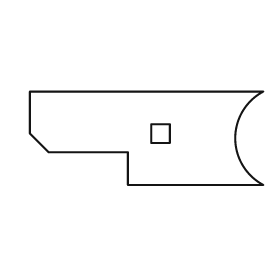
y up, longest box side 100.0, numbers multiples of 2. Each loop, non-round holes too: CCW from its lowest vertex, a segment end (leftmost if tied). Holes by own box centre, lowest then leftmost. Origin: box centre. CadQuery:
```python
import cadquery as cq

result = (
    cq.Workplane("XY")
    .moveTo(-8.0, -20.0)
    .lineTo(50.0, -20.0)
    .threePointArc((38.0, 0.0), (50.0, 20.0))
    .lineTo(-50.0, 20.0)
    .lineTo(-50.0, 2.0)
    .lineTo(-42.0, -6.0)
    .lineTo(-8.0, -6.0)
    .close()
    .moveTo(2.0, -2.0)
    .lineTo(10.0, -2.0)
    .lineTo(10.0, 6.0)
    .lineTo(2.0, 6.0)
    .close()
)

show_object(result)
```